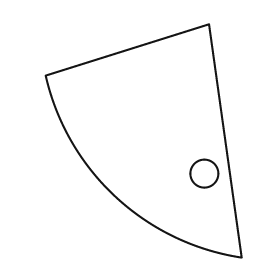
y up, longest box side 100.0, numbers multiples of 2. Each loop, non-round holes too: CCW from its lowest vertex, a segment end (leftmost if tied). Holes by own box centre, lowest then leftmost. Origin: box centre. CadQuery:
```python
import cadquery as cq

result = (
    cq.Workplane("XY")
    .moveTo(42.0, -50.0)
    .lineTo(28.0, 50.0)
    .lineTo(-42.0, 28.0)
    .threePointArc((-12.0, -24.0), (42.0, -50.0))
    .close()
    .moveTo(26.0, -14.0)
    .circle(6.0)
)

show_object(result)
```